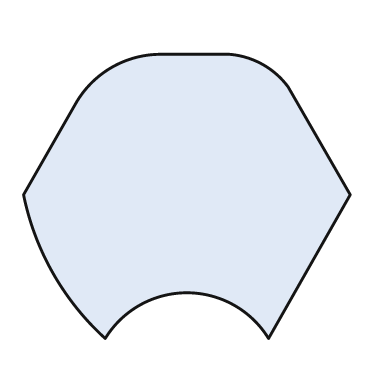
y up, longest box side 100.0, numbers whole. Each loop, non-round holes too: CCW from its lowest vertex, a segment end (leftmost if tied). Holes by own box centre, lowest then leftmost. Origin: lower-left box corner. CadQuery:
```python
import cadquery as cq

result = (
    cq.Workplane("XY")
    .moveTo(25.0, 0.0)
    .threePointArc((50.0, 14.0), (75.0, 0.0))
    .lineTo(100.0, 44.0)
    .lineTo(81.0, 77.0)
    .threePointArc((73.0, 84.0), (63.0, 87.0))
    .lineTo(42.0, 87.0)
    .threePointArc((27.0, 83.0), (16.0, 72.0))
    .lineTo(0.0, 44.0)
    .threePointArc((9.0, 20.0), (25.0, 0.0))
    .close()
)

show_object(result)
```